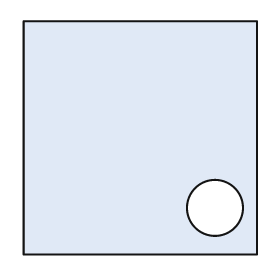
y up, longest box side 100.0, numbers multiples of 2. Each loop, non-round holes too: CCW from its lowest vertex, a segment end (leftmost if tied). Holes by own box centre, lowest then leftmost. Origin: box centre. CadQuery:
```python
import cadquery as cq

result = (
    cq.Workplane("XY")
    .moveTo(-50.0, -50.0)
    .lineTo(50.0, -50.0)
    .lineTo(50.0, 50.0)
    .lineTo(-50.0, 50.0)
    .close()
    .moveTo(32.0, -30.0)
    .circle(12.0)
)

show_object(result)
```